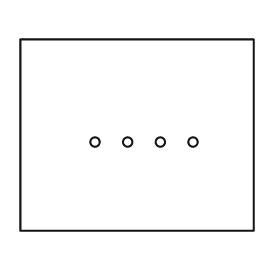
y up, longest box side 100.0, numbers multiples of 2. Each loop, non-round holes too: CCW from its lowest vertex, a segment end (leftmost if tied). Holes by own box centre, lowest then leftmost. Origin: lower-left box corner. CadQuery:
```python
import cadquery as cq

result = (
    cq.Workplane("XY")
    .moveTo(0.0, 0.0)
    .lineTo(100.0, 0.0)
    .lineTo(100.0, 82.0)
    .lineTo(0.0, 82.0)
    .close()
    .moveTo(32.0, 38.0)
    .circle(2.0)
    .moveTo(46.0, 38.0)
    .circle(2.0)
    .moveTo(60.0, 38.0)
    .circle(2.0)
    .moveTo(74.0, 38.0)
    .circle(2.0)
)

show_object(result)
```